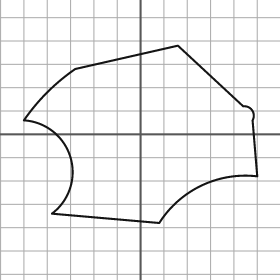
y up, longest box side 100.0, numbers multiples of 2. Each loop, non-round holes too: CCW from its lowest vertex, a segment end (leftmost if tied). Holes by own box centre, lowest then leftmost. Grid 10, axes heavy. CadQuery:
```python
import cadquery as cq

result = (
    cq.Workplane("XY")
    .moveTo(8.0, -38.0)
    .threePointArc((26.0, -22.0), (50.0, -18.0))
    .lineTo(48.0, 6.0)
    .threePointArc((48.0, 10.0), (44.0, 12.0))
    .lineTo(16.0, 38.0)
    .lineTo(-28.0, 28.0)
    .threePointArc((-40.0, 18.0), (-50.0, 6.0))
    .threePointArc((-30.0, -10.0), (-38.0, -34.0))
    .close()
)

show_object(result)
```